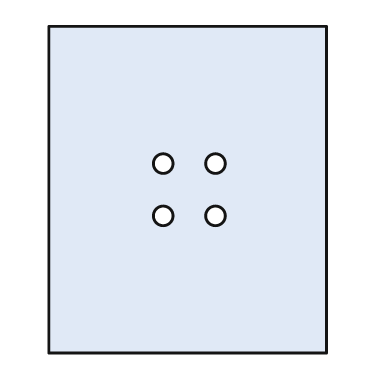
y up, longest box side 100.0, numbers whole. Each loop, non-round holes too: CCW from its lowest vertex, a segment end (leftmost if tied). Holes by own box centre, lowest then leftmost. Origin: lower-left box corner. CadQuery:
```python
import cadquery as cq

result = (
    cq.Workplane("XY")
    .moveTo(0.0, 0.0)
    .lineTo(85.0, 0.0)
    .lineTo(85.0, 100.0)
    .lineTo(0.0, 100.0)
    .close()
    .moveTo(35.0, 42.0)
    .circle(3.0)
    .moveTo(51.0, 42.0)
    .circle(3.0)
    .moveTo(35.0, 58.0)
    .circle(3.0)
    .moveTo(51.0, 58.0)
    .circle(3.0)
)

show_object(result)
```